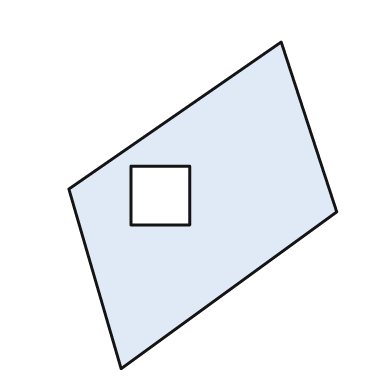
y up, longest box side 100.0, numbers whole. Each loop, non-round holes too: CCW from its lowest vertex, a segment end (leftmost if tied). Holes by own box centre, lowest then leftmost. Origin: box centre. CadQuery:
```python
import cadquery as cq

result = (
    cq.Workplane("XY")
    .moveTo(-25.0, -50.0)
    .lineTo(41.0, -2.0)
    .lineTo(24.0, 50.0)
    .lineTo(-41.0, 5.0)
    .close()
    .moveTo(-22.0, -6.0)
    .lineTo(-4.0, -6.0)
    .lineTo(-4.0, 12.0)
    .lineTo(-22.0, 12.0)
    .close()
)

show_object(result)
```